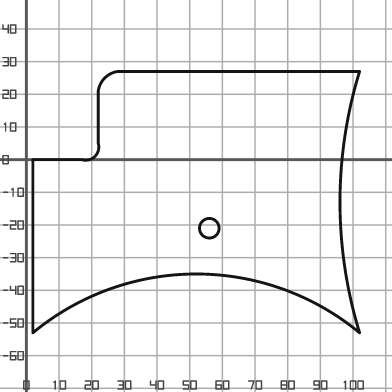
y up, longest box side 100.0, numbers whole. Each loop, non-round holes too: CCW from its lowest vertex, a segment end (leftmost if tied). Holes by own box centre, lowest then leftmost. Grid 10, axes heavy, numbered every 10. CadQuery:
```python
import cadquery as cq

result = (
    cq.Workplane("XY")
    .moveTo(2.0, -53.0)
    .threePointArc((52.0, -35.0), (102.0, -53.0))
    .threePointArc((96.0, -13.0), (102.0, 27.0))
    .lineTo(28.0, 27.0)
    .threePointArc((24.0, 25.0), (22.0, 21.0))
    .lineTo(22.0, 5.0)
    .threePointArc((21.0, 1.0), (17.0, 0.0))
    .lineTo(2.0, 0.0)
    .close()
    .moveTo(56.0, -21.0)
    .circle(3.0)
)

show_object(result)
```